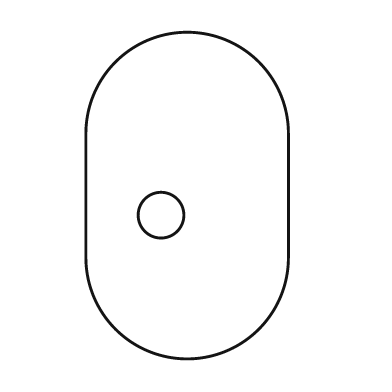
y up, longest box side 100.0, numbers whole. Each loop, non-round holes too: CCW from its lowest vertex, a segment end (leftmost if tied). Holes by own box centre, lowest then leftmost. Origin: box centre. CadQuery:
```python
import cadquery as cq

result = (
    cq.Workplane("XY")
    .moveTo(-31.0, -19.0)
    .threePointArc((0.0, -50.0), (31.0, -19.0))
    .lineTo(31.0, 19.0)
    .threePointArc((0.0, 50.0), (-31.0, 19.0))
    .close()
    .moveTo(-8.0, -6.0)
    .circle(7.0)
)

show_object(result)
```